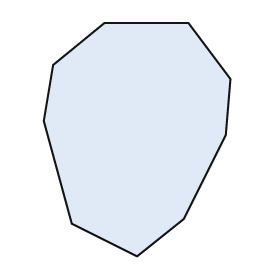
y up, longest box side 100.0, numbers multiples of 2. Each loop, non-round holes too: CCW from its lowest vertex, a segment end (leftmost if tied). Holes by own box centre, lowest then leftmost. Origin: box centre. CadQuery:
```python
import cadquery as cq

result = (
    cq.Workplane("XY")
    .moveTo(0.0, -50.0)
    .lineTo(20.0, -34.0)
    .lineTo(38.0, 2.0)
    .lineTo(40.0, 26.0)
    .lineTo(22.0, 50.0)
    .lineTo(-14.0, 50.0)
    .lineTo(-36.0, 32.0)
    .lineTo(-40.0, 8.0)
    .lineTo(-28.0, -36.0)
    .close()
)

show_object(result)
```